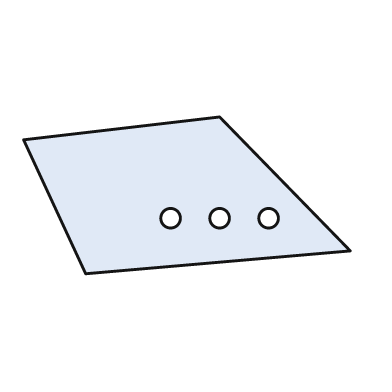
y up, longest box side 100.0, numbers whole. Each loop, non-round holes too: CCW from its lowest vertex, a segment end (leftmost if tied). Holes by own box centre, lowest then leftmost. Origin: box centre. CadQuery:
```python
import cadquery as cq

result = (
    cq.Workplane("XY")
    .moveTo(-31.0, -24.0)
    .lineTo(50.0, -17.0)
    .lineTo(10.0, 24.0)
    .lineTo(-50.0, 17.0)
    .close()
    .moveTo(-5.0, -7.0)
    .circle(3.0)
    .moveTo(10.0, -7.0)
    .circle(3.0)
    .moveTo(25.0, -7.0)
    .circle(3.0)
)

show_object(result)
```